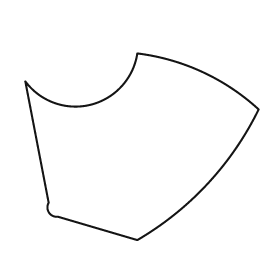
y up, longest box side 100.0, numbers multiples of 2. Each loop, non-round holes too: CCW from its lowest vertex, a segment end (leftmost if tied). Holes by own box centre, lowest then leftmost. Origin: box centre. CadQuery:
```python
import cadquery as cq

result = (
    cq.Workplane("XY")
    .moveTo(-2.0, -40.0)
    .threePointArc((28.0, -16.0), (50.0, 16.0))
    .threePointArc((26.0, 32.0), (-2.0, 40.0))
    .threePointArc((-22.0, 18.0), (-50.0, 28.0))
    .lineTo(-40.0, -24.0)
    .threePointArc((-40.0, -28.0), (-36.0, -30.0))
    .close()
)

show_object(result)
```